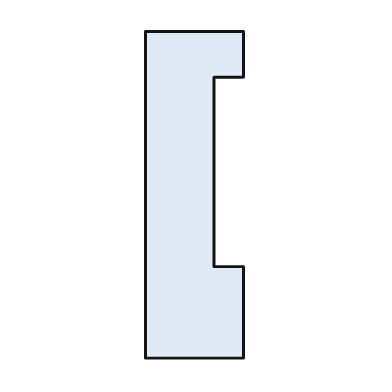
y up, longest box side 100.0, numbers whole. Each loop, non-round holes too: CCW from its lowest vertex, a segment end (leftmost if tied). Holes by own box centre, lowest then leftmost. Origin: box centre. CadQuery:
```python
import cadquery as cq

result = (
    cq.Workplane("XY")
    .moveTo(-15.0, -50.0)
    .lineTo(15.0, -50.0)
    .lineTo(15.0, -22.0)
    .lineTo(6.0, -22.0)
    .lineTo(6.0, 36.0)
    .lineTo(15.0, 36.0)
    .lineTo(15.0, 50.0)
    .lineTo(-15.0, 50.0)
    .close()
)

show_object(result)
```